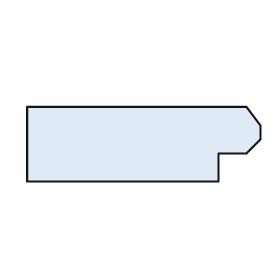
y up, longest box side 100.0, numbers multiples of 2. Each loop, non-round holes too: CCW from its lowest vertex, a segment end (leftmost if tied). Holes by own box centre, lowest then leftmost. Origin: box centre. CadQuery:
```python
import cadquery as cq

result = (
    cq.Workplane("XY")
    .moveTo(-50.0, -16.0)
    .lineTo(32.0, -16.0)
    .lineTo(32.0, -4.0)
    .lineTo(44.0, -4.0)
    .lineTo(50.0, 2.0)
    .lineTo(50.0, 8.0)
    .lineTo(44.0, 16.0)
    .lineTo(-50.0, 16.0)
    .close()
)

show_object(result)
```